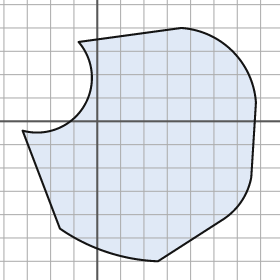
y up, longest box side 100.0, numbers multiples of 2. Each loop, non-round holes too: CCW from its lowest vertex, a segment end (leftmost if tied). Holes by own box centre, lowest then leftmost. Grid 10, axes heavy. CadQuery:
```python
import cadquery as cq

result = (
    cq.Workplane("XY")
    .moveTo(26.0, -60.0)
    .lineTo(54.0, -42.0)
    .threePointArc((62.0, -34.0), (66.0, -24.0))
    .lineTo(68.0, 8.0)
    .threePointArc((58.0, 30.0), (36.0, 40.0))
    .lineTo(-8.0, 34.0)
    .threePointArc((-6.0, 6.0), (-32.0, -4.0))
    .lineTo(-16.0, -46.0)
    .threePointArc((4.0, -56.0), (26.0, -60.0))
    .close()
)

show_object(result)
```